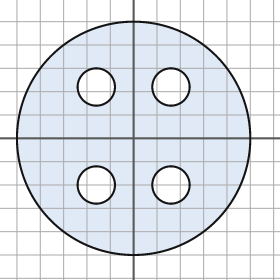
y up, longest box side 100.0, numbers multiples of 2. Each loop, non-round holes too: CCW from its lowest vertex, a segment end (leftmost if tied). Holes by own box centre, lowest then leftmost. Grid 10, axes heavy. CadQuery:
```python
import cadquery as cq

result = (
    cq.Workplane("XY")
    .moveTo(0.0, 0.0)
    .circle(50.0)
    .moveTo(-16.0, -20.0)
    .circle(8.0)
    .moveTo(16.0, -20.0)
    .circle(8.0)
    .moveTo(-16.0, 22.0)
    .circle(8.0)
    .moveTo(16.0, 22.0)
    .circle(8.0)
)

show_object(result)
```